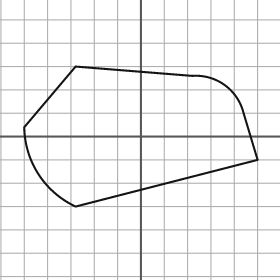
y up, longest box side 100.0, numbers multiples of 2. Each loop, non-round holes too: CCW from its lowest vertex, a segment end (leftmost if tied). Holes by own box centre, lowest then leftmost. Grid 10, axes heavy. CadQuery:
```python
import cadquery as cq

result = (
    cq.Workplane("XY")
    .moveTo(-28.0, -30.0)
    .lineTo(50.0, -10.0)
    .lineTo(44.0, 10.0)
    .threePointArc((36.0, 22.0), (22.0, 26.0))
    .lineTo(-28.0, 30.0)
    .lineTo(-50.0, 4.0)
    .threePointArc((-44.0, -16.0), (-28.0, -30.0))
    .close()
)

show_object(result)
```